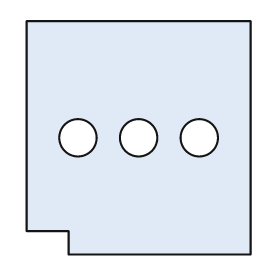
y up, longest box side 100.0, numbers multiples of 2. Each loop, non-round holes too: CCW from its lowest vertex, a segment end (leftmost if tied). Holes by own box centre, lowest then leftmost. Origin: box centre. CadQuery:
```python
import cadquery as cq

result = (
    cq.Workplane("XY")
    .moveTo(-30.0, -50.0)
    .lineTo(48.0, -50.0)
    .lineTo(48.0, 50.0)
    .lineTo(-48.0, 50.0)
    .lineTo(-48.0, -40.0)
    .lineTo(-30.0, -40.0)
    .close()
    .moveTo(-26.0, 0.0)
    .circle(8.0)
    .moveTo(0.0, 0.0)
    .circle(8.0)
    .moveTo(26.0, 0.0)
    .circle(8.0)
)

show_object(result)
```